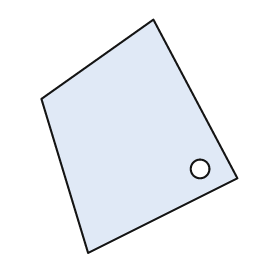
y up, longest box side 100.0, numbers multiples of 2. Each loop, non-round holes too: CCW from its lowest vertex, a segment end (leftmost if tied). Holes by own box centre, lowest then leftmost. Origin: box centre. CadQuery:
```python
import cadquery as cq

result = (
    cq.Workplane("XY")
    .moveTo(-22.0, -50.0)
    .lineTo(42.0, -18.0)
    .lineTo(6.0, 50.0)
    .lineTo(-42.0, 16.0)
    .close()
    .moveTo(26.0, -14.0)
    .circle(4.0)
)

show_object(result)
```